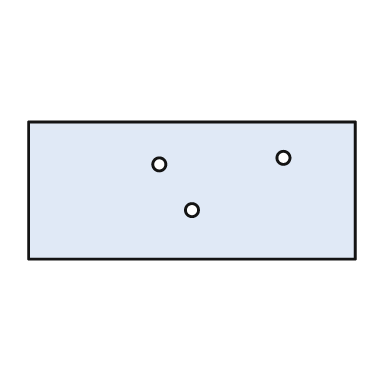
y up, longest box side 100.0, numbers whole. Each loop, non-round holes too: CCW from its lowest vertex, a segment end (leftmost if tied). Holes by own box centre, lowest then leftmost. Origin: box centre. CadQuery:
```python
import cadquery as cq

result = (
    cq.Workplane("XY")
    .moveTo(-50.0, -21.0)
    .lineTo(50.0, -21.0)
    .lineTo(50.0, 21.0)
    .lineTo(-50.0, 21.0)
    .close()
    .moveTo(0.0, -6.0)
    .circle(2.0)
    .moveTo(-10.0, 8.0)
    .circle(2.0)
    .moveTo(28.0, 10.0)
    .circle(2.0)
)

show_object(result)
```